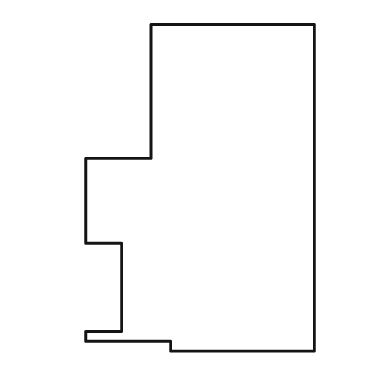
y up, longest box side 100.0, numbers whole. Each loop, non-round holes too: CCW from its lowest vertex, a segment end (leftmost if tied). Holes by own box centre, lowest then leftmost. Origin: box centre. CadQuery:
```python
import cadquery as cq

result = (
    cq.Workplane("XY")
    .moveTo(-9.0, -50.0)
    .lineTo(35.0, -50.0)
    .lineTo(35.0, 50.0)
    .lineTo(-15.0, 50.0)
    .lineTo(-15.0, 9.0)
    .lineTo(-35.0, 9.0)
    .lineTo(-35.0, -17.0)
    .lineTo(-24.0, -17.0)
    .lineTo(-24.0, -44.0)
    .lineTo(-35.0, -44.0)
    .lineTo(-35.0, -47.0)
    .lineTo(-9.0, -47.0)
    .close()
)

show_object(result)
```